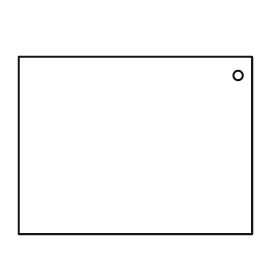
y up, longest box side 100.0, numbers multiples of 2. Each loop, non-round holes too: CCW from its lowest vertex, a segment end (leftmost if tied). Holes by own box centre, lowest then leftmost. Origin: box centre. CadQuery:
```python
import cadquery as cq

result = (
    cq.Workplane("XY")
    .moveTo(-50.0, -38.0)
    .lineTo(50.0, -38.0)
    .lineTo(50.0, 38.0)
    .lineTo(-50.0, 38.0)
    .close()
    .moveTo(44.0, 30.0)
    .circle(2.0)
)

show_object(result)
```